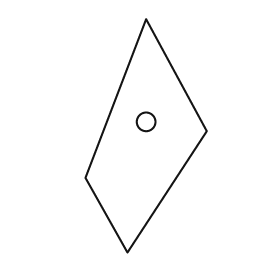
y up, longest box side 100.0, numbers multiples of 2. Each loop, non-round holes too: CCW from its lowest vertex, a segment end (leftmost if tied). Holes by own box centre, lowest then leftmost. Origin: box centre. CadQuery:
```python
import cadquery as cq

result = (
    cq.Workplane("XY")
    .moveTo(-8.0, -50.0)
    .lineTo(26.0, 2.0)
    .lineTo(0.0, 50.0)
    .lineTo(-26.0, -18.0)
    .close()
    .moveTo(0.0, 6.0)
    .circle(4.0)
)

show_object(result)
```